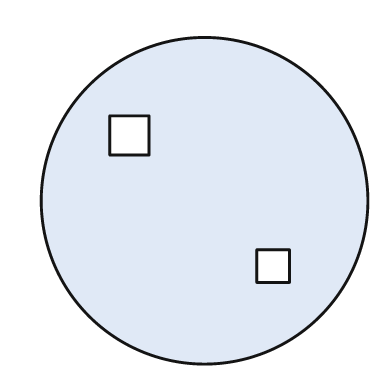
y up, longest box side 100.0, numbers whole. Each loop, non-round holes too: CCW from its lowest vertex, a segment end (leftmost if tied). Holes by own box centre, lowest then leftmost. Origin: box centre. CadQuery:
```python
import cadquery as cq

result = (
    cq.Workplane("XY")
    .moveTo(0.0, 0.0)
    .circle(50.0)
    .moveTo(16.0, -25.0)
    .lineTo(26.0, -25.0)
    .lineTo(26.0, -15.0)
    .lineTo(16.0, -15.0)
    .close()
    .moveTo(-29.0, 14.0)
    .lineTo(-17.0, 14.0)
    .lineTo(-17.0, 26.0)
    .lineTo(-29.0, 26.0)
    .close()
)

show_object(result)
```